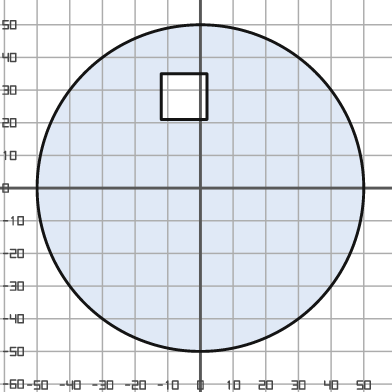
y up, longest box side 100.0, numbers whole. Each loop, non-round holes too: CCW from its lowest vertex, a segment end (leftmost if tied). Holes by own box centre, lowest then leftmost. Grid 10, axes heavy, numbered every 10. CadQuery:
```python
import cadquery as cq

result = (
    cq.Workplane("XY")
    .moveTo(0.0, 0.0)
    .circle(50.0)
    .moveTo(-12.0, 21.0)
    .lineTo(2.0, 21.0)
    .lineTo(2.0, 35.0)
    .lineTo(-12.0, 35.0)
    .close()
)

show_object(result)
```